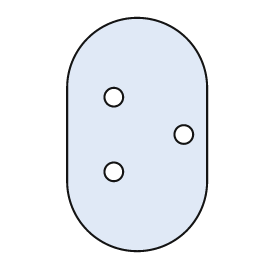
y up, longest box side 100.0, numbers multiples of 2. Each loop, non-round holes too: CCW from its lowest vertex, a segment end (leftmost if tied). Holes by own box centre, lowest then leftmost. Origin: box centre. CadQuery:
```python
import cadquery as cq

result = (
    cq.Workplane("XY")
    .moveTo(-30.0, -20.0)
    .threePointArc((0.0, -50.0), (30.0, -20.0))
    .lineTo(30.0, 20.0)
    .threePointArc((0.0, 50.0), (-30.0, 20.0))
    .close()
    .moveTo(-10.0, -16.0)
    .circle(4.0)
    .moveTo(20.0, 0.0)
    .circle(4.0)
    .moveTo(-10.0, 16.0)
    .circle(4.0)
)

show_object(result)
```